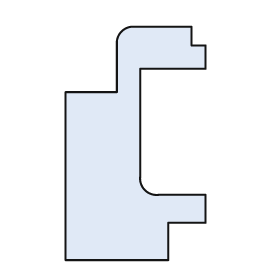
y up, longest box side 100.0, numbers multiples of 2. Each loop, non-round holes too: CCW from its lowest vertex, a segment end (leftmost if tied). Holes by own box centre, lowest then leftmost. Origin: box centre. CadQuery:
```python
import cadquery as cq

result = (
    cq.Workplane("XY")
    .moveTo(-30.0, -50.0)
    .lineTo(14.0, -50.0)
    .lineTo(14.0, -34.0)
    .lineTo(30.0, -34.0)
    .lineTo(30.0, -22.0)
    .lineTo(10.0, -22.0)
    .threePointArc((4.0, -20.0), (2.0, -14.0))
    .lineTo(2.0, 32.0)
    .lineTo(30.0, 32.0)
    .lineTo(30.0, 42.0)
    .lineTo(24.0, 42.0)
    .lineTo(24.0, 50.0)
    .lineTo(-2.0, 50.0)
    .threePointArc((-6.0, 48.0), (-8.0, 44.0))
    .lineTo(-8.0, 22.0)
    .lineTo(-30.0, 22.0)
    .close()
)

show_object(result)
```